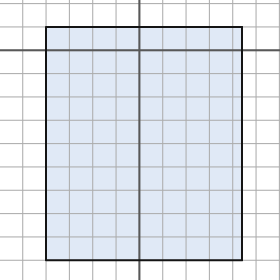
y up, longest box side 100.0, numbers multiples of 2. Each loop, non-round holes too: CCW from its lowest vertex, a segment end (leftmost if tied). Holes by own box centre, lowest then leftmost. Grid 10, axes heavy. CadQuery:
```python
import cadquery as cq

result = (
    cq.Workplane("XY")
    .moveTo(-40.0, -90.0)
    .lineTo(44.0, -90.0)
    .lineTo(44.0, 10.0)
    .lineTo(-40.0, 10.0)
    .close()
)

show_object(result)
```